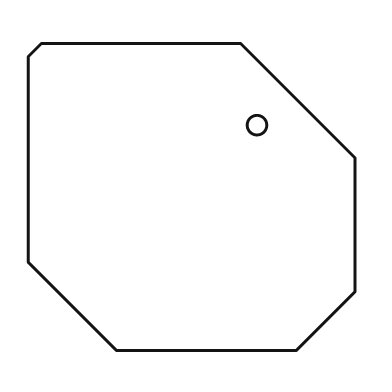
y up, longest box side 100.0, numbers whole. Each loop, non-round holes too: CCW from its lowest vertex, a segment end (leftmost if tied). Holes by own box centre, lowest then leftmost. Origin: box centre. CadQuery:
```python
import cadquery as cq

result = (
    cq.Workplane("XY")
    .moveTo(-23.0, -47.0)
    .lineTo(32.0, -47.0)
    .lineTo(50.0, -29.0)
    .lineTo(50.0, 12.0)
    .lineTo(15.0, 47.0)
    .lineTo(-46.0, 47.0)
    .lineTo(-50.0, 43.0)
    .lineTo(-50.0, -20.0)
    .close()
    .moveTo(20.0, 22.0)
    .circle(3.0)
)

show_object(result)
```